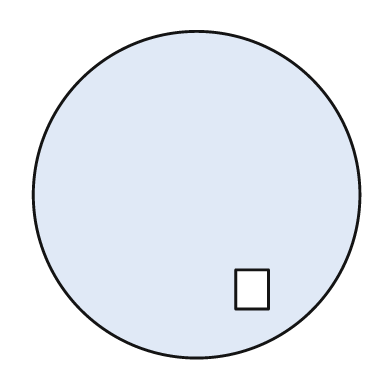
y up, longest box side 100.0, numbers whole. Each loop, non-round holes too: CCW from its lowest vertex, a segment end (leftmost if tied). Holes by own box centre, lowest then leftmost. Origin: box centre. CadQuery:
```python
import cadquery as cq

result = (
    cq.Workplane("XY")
    .moveTo(0.0, 0.0)
    .circle(50.0)
    .moveTo(12.0, -35.0)
    .lineTo(22.0, -35.0)
    .lineTo(22.0, -23.0)
    .lineTo(12.0, -23.0)
    .close()
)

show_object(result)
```